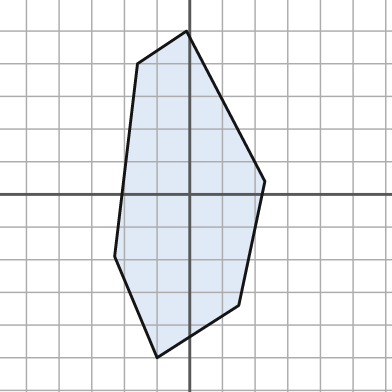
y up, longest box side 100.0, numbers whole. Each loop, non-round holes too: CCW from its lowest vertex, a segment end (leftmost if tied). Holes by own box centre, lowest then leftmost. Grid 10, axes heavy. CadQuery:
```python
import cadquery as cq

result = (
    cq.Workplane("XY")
    .moveTo(-10.0, -50.0)
    .lineTo(15.0, -34.0)
    .lineTo(23.0, 4.0)
    .lineTo(-1.0, 50.0)
    .lineTo(-16.0, 40.0)
    .lineTo(-23.0, -19.0)
    .close()
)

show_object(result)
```